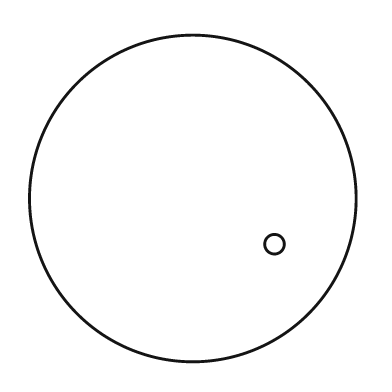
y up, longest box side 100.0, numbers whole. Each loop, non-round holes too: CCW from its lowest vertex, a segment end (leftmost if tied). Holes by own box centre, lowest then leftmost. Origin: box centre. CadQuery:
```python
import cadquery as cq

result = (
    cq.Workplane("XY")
    .moveTo(0.0, 0.0)
    .circle(50.0)
    .moveTo(25.0, -14.0)
    .circle(3.0)
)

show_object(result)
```